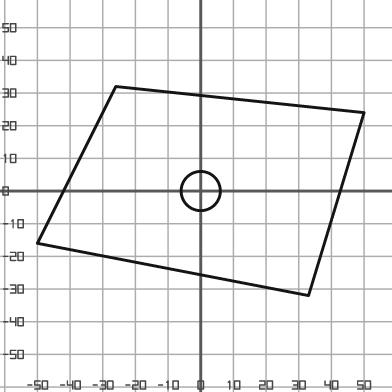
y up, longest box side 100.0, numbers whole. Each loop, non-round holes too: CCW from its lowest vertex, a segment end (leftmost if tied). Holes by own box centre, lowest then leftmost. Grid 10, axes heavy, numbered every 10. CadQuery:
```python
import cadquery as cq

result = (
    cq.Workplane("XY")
    .moveTo(33.0, -32.0)
    .lineTo(50.0, 24.0)
    .lineTo(-26.0, 32.0)
    .lineTo(-50.0, -16.0)
    .close()
    .moveTo(0.0, 0.0)
    .circle(6.0)
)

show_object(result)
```